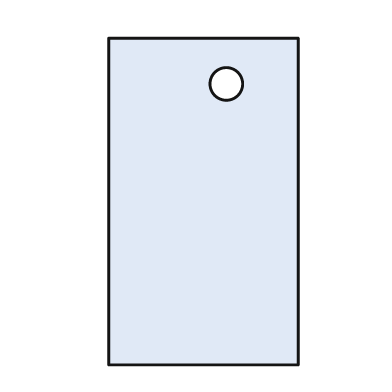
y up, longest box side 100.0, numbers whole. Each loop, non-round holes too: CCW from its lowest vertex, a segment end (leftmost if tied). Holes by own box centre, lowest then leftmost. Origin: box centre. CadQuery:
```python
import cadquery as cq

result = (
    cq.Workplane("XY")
    .moveTo(-29.0, -50.0)
    .lineTo(29.0, -50.0)
    .lineTo(29.0, 50.0)
    .lineTo(-29.0, 50.0)
    .close()
    .moveTo(7.0, 36.0)
    .circle(5.0)
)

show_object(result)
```